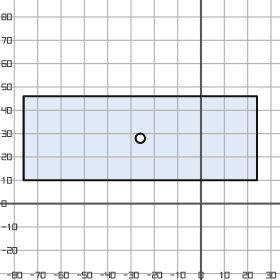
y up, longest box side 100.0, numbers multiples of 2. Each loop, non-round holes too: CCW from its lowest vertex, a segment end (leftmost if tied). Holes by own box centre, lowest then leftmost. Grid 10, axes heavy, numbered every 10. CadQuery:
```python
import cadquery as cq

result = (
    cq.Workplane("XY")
    .moveTo(-76.0, 10.0)
    .lineTo(24.0, 10.0)
    .lineTo(24.0, 46.0)
    .lineTo(-76.0, 46.0)
    .close()
    .moveTo(-26.0, 28.0)
    .circle(2.0)
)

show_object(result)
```